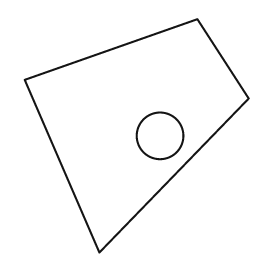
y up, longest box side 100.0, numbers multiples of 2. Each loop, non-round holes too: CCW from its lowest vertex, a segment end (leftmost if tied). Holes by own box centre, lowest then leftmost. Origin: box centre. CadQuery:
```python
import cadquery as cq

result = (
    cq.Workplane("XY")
    .moveTo(-16.0, -50.0)
    .lineTo(48.0, 16.0)
    .lineTo(26.0, 50.0)
    .lineTo(-48.0, 24.0)
    .close()
    .moveTo(10.0, 0.0)
    .circle(10.0)
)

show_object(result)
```